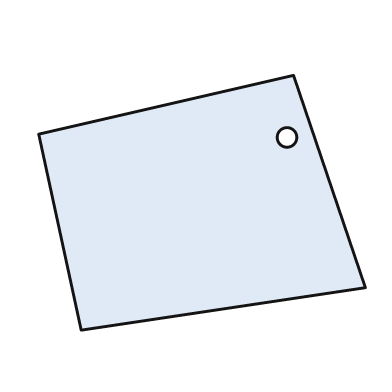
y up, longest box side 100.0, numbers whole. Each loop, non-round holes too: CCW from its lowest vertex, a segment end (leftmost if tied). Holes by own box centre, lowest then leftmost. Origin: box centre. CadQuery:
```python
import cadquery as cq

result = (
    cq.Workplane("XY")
    .moveTo(-37.0, -39.0)
    .lineTo(50.0, -26.0)
    .lineTo(28.0, 39.0)
    .lineTo(-50.0, 21.0)
    .close()
    .moveTo(26.0, 20.0)
    .circle(3.0)
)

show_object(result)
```